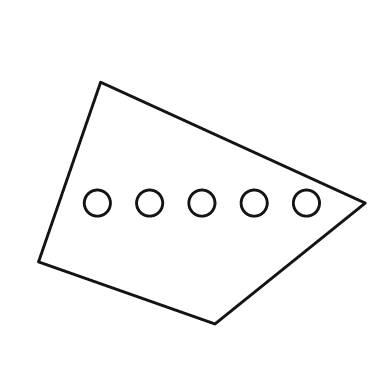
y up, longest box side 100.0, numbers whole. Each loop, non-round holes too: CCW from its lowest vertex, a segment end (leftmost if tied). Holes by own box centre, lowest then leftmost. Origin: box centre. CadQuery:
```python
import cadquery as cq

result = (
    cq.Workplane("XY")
    .moveTo(4.0, -37.0)
    .lineTo(50.0, 0.0)
    .lineTo(-31.0, 37.0)
    .lineTo(-50.0, -18.0)
    .close()
    .moveTo(-32.0, 0.0)
    .circle(4.0)
    .moveTo(-16.0, 0.0)
    .circle(4.0)
    .moveTo(0.0, 0.0)
    .circle(4.0)
    .moveTo(16.0, 0.0)
    .circle(4.0)
    .moveTo(32.0, 0.0)
    .circle(4.0)
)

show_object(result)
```